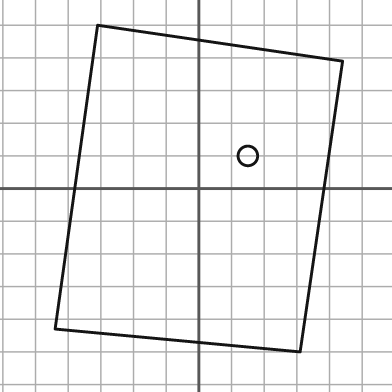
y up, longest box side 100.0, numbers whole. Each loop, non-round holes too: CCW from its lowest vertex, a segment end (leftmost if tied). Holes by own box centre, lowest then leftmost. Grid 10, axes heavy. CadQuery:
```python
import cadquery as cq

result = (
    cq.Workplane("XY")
    .moveTo(31.0, -50.0)
    .lineTo(44.0, 39.0)
    .lineTo(-31.0, 50.0)
    .lineTo(-44.0, -43.0)
    .close()
    .moveTo(15.0, 10.0)
    .circle(3.0)
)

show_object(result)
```